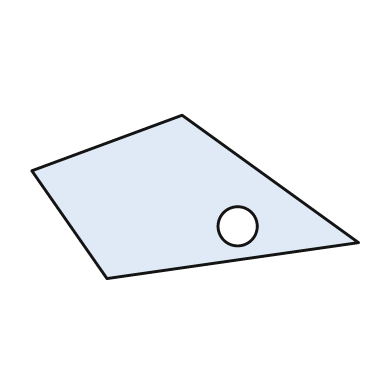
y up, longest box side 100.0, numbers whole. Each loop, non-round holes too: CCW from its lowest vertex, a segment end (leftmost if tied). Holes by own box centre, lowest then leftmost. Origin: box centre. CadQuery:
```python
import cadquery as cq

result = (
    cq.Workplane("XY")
    .moveTo(-27.0, -25.0)
    .lineTo(50.0, -14.0)
    .lineTo(-4.0, 25.0)
    .lineTo(-50.0, 8.0)
    .close()
    .moveTo(13.0, -9.0)
    .circle(6.0)
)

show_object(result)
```